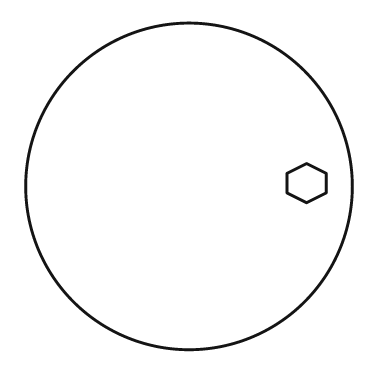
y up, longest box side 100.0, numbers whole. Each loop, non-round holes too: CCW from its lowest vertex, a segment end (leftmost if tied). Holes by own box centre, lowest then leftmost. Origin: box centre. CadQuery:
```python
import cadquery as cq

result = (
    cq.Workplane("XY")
    .moveTo(0.0, 0.0)
    .circle(50.0)
    .moveTo(36.0, -5.0)
    .lineTo(42.0, -2.0)
    .lineTo(42.0, 4.0)
    .lineTo(36.0, 7.0)
    .lineTo(30.0, 4.0)
    .lineTo(30.0, -2.0)
    .close()
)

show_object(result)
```